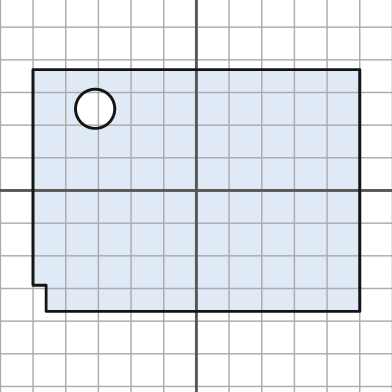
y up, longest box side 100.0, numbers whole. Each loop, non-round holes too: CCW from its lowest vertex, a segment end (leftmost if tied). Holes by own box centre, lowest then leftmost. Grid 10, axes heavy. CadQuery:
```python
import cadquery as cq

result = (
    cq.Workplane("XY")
    .moveTo(-46.0, -37.0)
    .lineTo(50.0, -37.0)
    .lineTo(50.0, 37.0)
    .lineTo(-50.0, 37.0)
    .lineTo(-50.0, -29.0)
    .lineTo(-46.0, -29.0)
    .close()
    .moveTo(-31.0, 25.0)
    .circle(6.0)
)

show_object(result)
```